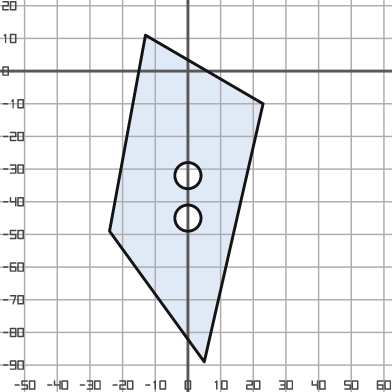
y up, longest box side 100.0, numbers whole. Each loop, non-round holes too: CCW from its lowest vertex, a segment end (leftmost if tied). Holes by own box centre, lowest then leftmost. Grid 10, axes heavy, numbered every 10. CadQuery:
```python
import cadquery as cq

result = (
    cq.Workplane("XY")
    .moveTo(5.0, -89.0)
    .lineTo(23.0, -10.0)
    .lineTo(-13.0, 11.0)
    .lineTo(-24.0, -49.0)
    .close()
    .moveTo(0.0, -45.0)
    .circle(4.0)
    .moveTo(0.0, -32.0)
    .circle(4.0)
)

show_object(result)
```